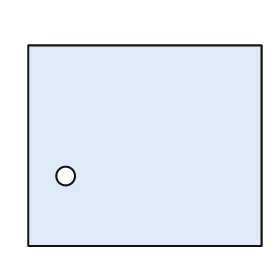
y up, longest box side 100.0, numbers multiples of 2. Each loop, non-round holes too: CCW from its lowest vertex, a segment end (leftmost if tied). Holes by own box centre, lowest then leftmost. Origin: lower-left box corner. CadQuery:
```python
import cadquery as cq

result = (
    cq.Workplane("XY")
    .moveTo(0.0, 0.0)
    .lineTo(100.0, 0.0)
    .lineTo(100.0, 86.0)
    .lineTo(0.0, 86.0)
    .close()
    .moveTo(16.0, 30.0)
    .circle(4.0)
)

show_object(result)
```